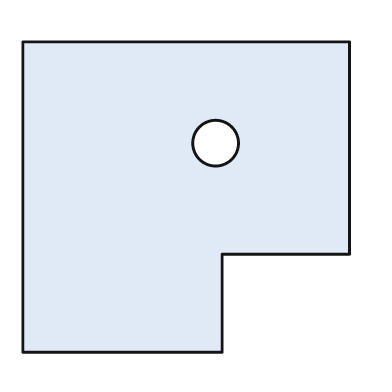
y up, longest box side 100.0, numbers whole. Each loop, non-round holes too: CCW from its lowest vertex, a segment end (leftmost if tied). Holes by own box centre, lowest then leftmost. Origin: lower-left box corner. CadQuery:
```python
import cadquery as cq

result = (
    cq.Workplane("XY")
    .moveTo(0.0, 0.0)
    .lineTo(61.0, 0.0)
    .lineTo(61.0, 30.0)
    .lineTo(100.0, 30.0)
    .lineTo(100.0, 95.0)
    .lineTo(0.0, 95.0)
    .close()
    .moveTo(59.0, 64.0)
    .circle(7.0)
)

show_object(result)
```